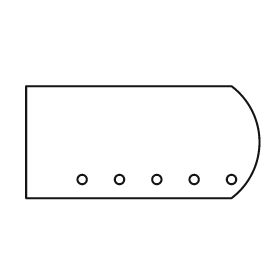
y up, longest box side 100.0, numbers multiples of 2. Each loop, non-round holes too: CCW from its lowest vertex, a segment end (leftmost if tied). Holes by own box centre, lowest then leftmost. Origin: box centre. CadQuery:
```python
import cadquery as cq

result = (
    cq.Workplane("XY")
    .moveTo(-50.0, -24.0)
    .lineTo(38.0, -24.0)
    .threePointArc((50.0, 0.0), (38.0, 24.0))
    .lineTo(-50.0, 24.0)
    .close()
    .moveTo(-26.0, -16.0)
    .circle(2.0)
    .moveTo(-10.0, -16.0)
    .circle(2.0)
    .moveTo(6.0, -16.0)
    .circle(2.0)
    .moveTo(22.0, -16.0)
    .circle(2.0)
    .moveTo(38.0, -16.0)
    .circle(2.0)
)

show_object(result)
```